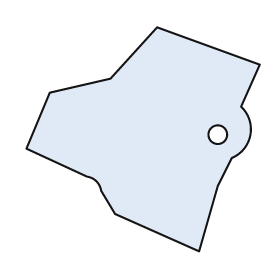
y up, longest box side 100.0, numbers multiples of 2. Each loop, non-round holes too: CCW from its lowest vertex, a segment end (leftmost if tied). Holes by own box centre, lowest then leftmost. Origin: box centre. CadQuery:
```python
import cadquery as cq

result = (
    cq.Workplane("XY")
    .moveTo(24.0, -48.0)
    .lineTo(32.0, -20.0)
    .lineTo(38.0, -8.0)
    .threePointArc((46.0, 2.0), (42.0, 14.0))
    .lineTo(50.0, 32.0)
    .lineTo(6.0, 48.0)
    .lineTo(-14.0, 26.0)
    .lineTo(-40.0, 20.0)
    .lineTo(-50.0, -4.0)
    .lineTo(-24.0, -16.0)
    .threePointArc((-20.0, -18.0), (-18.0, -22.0))
    .lineTo(-12.0, -32.0)
    .close()
    .moveTo(32.0, 2.0)
    .circle(4.0)
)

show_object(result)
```